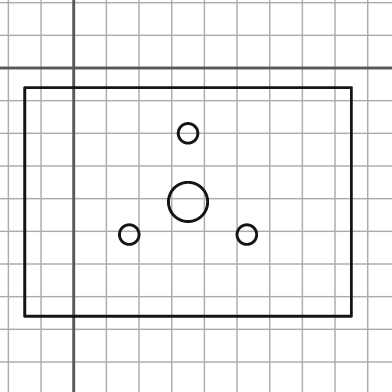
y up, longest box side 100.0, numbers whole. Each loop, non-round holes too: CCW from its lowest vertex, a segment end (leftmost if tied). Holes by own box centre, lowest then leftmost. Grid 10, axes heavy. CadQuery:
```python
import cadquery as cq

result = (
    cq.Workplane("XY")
    .moveTo(-15.0, -76.0)
    .lineTo(85.0, -76.0)
    .lineTo(85.0, -6.0)
    .lineTo(-15.0, -6.0)
    .close()
    .moveTo(17.0, -51.0)
    .circle(3.0)
    .moveTo(53.0, -51.0)
    .circle(3.0)
    .moveTo(35.0, -41.0)
    .circle(6.0)
    .moveTo(35.0, -20.0)
    .circle(3.0)
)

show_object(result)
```